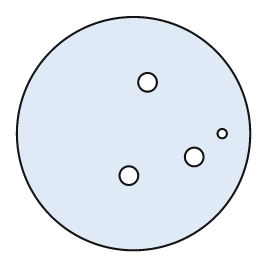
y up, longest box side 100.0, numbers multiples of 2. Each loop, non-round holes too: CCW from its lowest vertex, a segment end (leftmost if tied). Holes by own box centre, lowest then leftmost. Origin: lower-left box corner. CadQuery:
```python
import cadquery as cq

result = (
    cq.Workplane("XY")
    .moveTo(50.0, 50.0)
    .circle(50.0)
    .moveTo(48.0, 32.0)
    .circle(4.0)
    .moveTo(76.0, 40.0)
    .circle(4.0)
    .moveTo(88.0, 50.0)
    .circle(2.0)
    .moveTo(56.0, 72.0)
    .circle(4.0)
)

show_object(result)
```